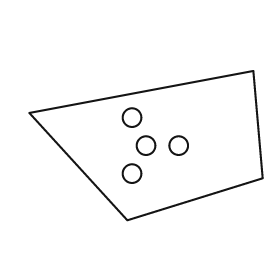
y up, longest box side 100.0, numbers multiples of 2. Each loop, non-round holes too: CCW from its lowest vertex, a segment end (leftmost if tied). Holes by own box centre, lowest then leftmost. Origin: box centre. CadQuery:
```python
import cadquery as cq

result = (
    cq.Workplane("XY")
    .moveTo(-8.0, -32.0)
    .lineTo(50.0, -14.0)
    .lineTo(46.0, 32.0)
    .lineTo(-50.0, 14.0)
    .close()
    .moveTo(-6.0, -12.0)
    .circle(4.0)
    .moveTo(0.0, 0.0)
    .circle(4.0)
    .moveTo(14.0, 0.0)
    .circle(4.0)
    .moveTo(-6.0, 12.0)
    .circle(4.0)
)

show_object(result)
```